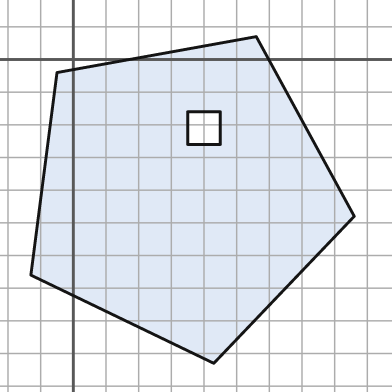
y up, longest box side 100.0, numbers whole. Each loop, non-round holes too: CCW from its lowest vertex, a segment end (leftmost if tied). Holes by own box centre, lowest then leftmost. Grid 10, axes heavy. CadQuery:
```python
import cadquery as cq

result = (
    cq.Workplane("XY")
    .moveTo(43.0, -93.0)
    .lineTo(86.0, -48.0)
    .lineTo(56.0, 7.0)
    .lineTo(-5.0, -4.0)
    .lineTo(-13.0, -66.0)
    .close()
    .moveTo(35.0, -26.0)
    .lineTo(45.0, -26.0)
    .lineTo(45.0, -16.0)
    .lineTo(35.0, -16.0)
    .close()
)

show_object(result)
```